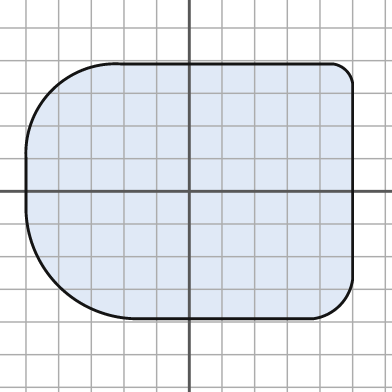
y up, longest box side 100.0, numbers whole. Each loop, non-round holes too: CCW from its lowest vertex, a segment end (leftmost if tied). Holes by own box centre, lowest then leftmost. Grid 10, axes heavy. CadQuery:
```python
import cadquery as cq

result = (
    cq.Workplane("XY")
    .moveTo(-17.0, -39.0)
    .lineTo(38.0, -39.0)
    .threePointArc((46.0, -35.0), (50.0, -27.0))
    .lineTo(50.0, 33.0)
    .threePointArc((48.0, 37.0), (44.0, 39.0))
    .lineTo(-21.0, 39.0)
    .threePointArc((-42.0, 31.0), (-50.0, 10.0))
    .lineTo(-50.0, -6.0)
    .threePointArc((-40.0, -29.0), (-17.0, -39.0))
    .close()
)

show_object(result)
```